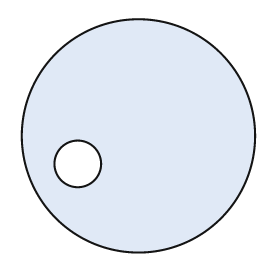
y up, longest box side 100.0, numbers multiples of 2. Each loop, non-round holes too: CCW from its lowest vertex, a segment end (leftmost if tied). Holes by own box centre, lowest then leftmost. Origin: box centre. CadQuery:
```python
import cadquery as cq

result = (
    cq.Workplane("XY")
    .moveTo(0.0, 0.0)
    .circle(50.0)
    .moveTo(-26.0, -12.0)
    .circle(10.0)
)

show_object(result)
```